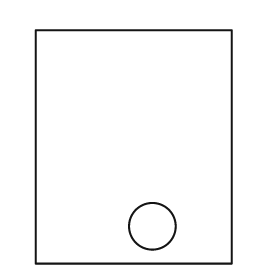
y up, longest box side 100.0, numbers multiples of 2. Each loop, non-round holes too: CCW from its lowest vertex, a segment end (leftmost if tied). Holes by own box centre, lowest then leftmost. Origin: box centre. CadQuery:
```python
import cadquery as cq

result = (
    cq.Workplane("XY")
    .moveTo(-42.0, -50.0)
    .lineTo(42.0, -50.0)
    .lineTo(42.0, 50.0)
    .lineTo(-42.0, 50.0)
    .close()
    .moveTo(8.0, -34.0)
    .circle(10.0)
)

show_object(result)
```